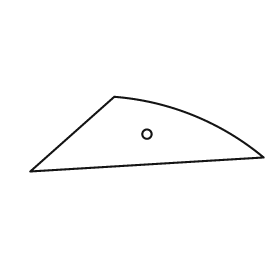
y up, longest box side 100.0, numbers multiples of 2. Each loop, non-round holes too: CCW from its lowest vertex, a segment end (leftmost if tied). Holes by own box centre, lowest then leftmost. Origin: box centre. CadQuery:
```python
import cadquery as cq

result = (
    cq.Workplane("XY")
    .moveTo(-50.0, -16.0)
    .lineTo(50.0, -10.0)
    .threePointArc((20.0, 8.0), (-14.0, 16.0))
    .close()
    .moveTo(0.0, 0.0)
    .circle(2.0)
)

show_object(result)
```